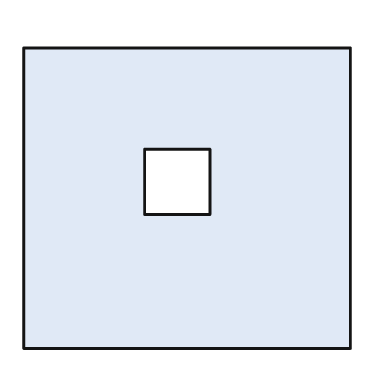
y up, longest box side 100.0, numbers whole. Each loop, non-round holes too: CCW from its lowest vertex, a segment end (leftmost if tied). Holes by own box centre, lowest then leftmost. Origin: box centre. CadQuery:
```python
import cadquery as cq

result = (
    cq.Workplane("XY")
    .moveTo(-50.0, -46.0)
    .lineTo(50.0, -46.0)
    .lineTo(50.0, 46.0)
    .lineTo(-50.0, 46.0)
    .close()
    .moveTo(-13.0, -5.0)
    .lineTo(7.0, -5.0)
    .lineTo(7.0, 15.0)
    .lineTo(-13.0, 15.0)
    .close()
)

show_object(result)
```